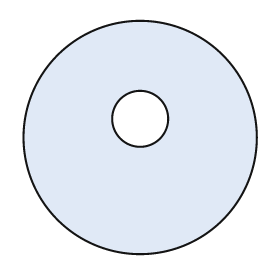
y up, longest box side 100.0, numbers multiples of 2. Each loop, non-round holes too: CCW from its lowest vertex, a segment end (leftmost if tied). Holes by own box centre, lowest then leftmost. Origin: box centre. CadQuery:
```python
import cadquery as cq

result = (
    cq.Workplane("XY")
    .moveTo(0.0, 0.0)
    .circle(50.0)
    .moveTo(0.0, 8.0)
    .circle(12.0)
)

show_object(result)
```